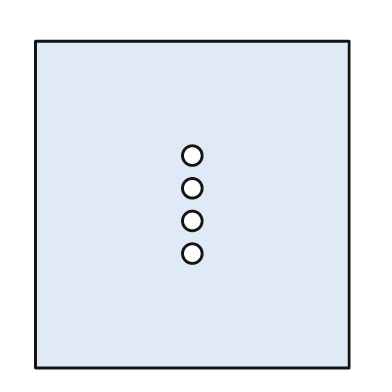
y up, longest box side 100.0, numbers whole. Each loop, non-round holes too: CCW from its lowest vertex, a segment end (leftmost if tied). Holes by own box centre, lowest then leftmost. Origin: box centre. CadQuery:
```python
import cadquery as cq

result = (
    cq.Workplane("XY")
    .moveTo(-48.0, -50.0)
    .lineTo(48.0, -50.0)
    .lineTo(48.0, 50.0)
    .lineTo(-48.0, 50.0)
    .close()
    .moveTo(0.0, -15.0)
    .circle(3.0)
    .moveTo(0.0, -5.0)
    .circle(3.0)
    .moveTo(0.0, 5.0)
    .circle(3.0)
    .moveTo(0.0, 15.0)
    .circle(3.0)
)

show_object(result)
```